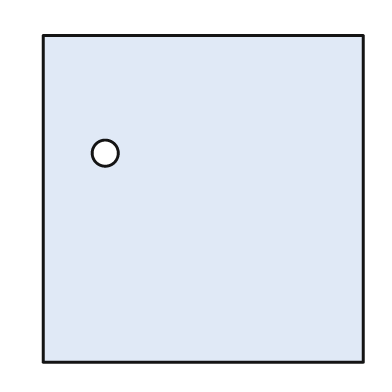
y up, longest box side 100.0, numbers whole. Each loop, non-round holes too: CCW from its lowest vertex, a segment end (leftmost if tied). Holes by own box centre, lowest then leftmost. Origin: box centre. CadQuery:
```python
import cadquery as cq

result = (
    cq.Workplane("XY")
    .moveTo(-49.0, -50.0)
    .lineTo(49.0, -50.0)
    .lineTo(49.0, 50.0)
    .lineTo(-49.0, 50.0)
    .close()
    .moveTo(-30.0, 14.0)
    .circle(4.0)
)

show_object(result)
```